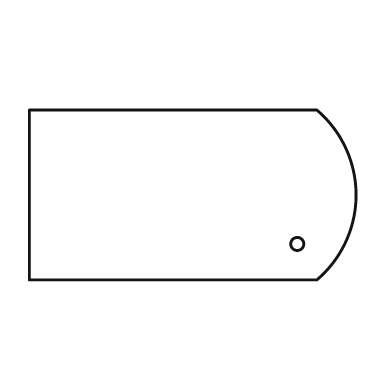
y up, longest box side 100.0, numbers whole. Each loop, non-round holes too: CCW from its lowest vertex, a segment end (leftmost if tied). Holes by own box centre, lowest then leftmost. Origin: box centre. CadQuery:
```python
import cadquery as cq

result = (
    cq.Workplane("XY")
    .moveTo(-50.0, -26.0)
    .lineTo(38.0, -26.0)
    .threePointArc((50.0, 0.0), (38.0, 26.0))
    .lineTo(-50.0, 26.0)
    .close()
    .moveTo(32.0, -15.0)
    .circle(2.0)
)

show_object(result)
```